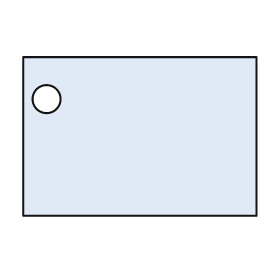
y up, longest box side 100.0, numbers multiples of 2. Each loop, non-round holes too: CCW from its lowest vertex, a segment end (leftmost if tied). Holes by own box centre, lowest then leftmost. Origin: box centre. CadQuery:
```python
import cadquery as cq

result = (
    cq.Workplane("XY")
    .moveTo(-50.0, -34.0)
    .lineTo(50.0, -34.0)
    .lineTo(50.0, 34.0)
    .lineTo(-50.0, 34.0)
    .close()
    .moveTo(-40.0, 16.0)
    .circle(6.0)
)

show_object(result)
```